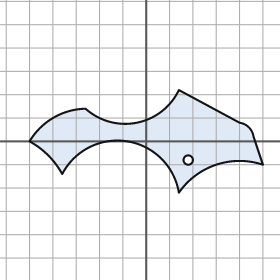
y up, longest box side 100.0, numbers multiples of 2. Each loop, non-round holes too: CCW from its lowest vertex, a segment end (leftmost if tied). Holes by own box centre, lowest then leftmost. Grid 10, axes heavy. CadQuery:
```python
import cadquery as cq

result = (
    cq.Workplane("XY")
    .moveTo(14.0, -22.0)
    .threePointArc((30.0, -10.0), (50.0, -10.0))
    .lineTo(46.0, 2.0)
    .threePointArc((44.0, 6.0), (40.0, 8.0))
    .lineTo(14.0, 22.0)
    .threePointArc((-4.0, 8.0), (-26.0, 14.0))
    .threePointArc((-40.0, 10.0), (-50.0, 0.0))
    .threePointArc((-42.0, -6.0), (-36.0, -14.0))
    .threePointArc((-8.0, 0.0), (14.0, -22.0))
    .close()
    .moveTo(18.0, -8.0)
    .circle(2.0)
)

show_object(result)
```